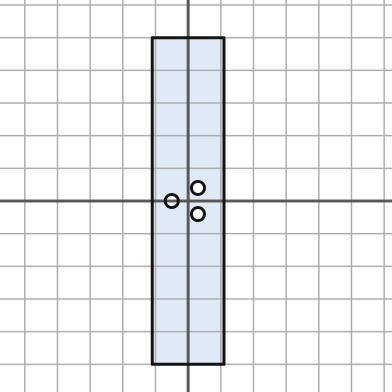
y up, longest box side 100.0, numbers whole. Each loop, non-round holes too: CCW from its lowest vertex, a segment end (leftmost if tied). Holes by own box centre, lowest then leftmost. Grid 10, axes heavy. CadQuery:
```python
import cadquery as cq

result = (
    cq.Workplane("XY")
    .moveTo(-11.0, -50.0)
    .lineTo(11.0, -50.0)
    .lineTo(11.0, 50.0)
    .lineTo(-11.0, 50.0)
    .close()
    .moveTo(3.0, -4.0)
    .circle(2.0)
    .moveTo(-5.0, 0.0)
    .circle(2.0)
    .moveTo(3.0, 4.0)
    .circle(2.0)
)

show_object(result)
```